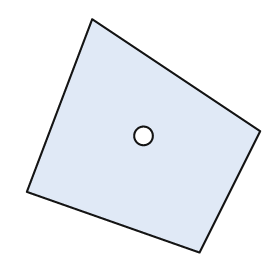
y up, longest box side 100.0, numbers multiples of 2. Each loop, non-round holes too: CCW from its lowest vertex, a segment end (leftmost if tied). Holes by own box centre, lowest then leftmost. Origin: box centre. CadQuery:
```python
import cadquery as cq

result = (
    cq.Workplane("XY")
    .moveTo(24.0, -50.0)
    .lineTo(50.0, 2.0)
    .lineTo(-22.0, 50.0)
    .lineTo(-50.0, -24.0)
    .close()
    .moveTo(0.0, 0.0)
    .circle(4.0)
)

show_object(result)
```